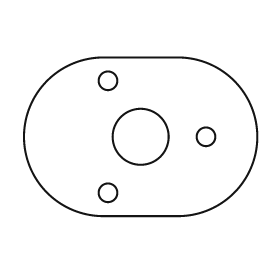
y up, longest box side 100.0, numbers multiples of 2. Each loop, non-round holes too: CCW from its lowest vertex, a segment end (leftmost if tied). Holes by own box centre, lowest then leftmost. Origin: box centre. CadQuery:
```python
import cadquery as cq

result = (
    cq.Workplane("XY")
    .moveTo(-16.0, -34.0)
    .lineTo(16.0, -34.0)
    .threePointArc((50.0, 0.0), (16.0, 34.0))
    .lineTo(-16.0, 34.0)
    .threePointArc((-50.0, 0.0), (-16.0, -34.0))
    .close()
    .moveTo(-14.0, -24.0)
    .circle(4.0)
    .moveTo(0.0, 0.0)
    .circle(12.0)
    .moveTo(28.0, 0.0)
    .circle(4.0)
    .moveTo(-14.0, 24.0)
    .circle(4.0)
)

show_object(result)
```